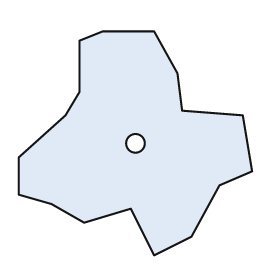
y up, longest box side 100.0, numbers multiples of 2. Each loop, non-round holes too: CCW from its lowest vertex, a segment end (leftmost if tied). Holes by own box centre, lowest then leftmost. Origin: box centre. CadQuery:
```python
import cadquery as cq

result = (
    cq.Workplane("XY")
    .moveTo(8.0, -48.0)
    .lineTo(24.0, -40.0)
    .lineTo(36.0, -18.0)
    .lineTo(50.0, -12.0)
    .lineTo(46.0, 12.0)
    .lineTo(20.0, 14.0)
    .lineTo(18.0, 30.0)
    .lineTo(8.0, 48.0)
    .lineTo(-14.0, 48.0)
    .lineTo(-24.0, 44.0)
    .lineTo(-24.0, 22.0)
    .lineTo(-30.0, 12.0)
    .lineTo(-50.0, -6.0)
    .lineTo(-50.0, -22.0)
    .lineTo(-36.0, -26.0)
    .lineTo(-22.0, -34.0)
    .lineTo(-2.0, -28.0)
    .close()
    .moveTo(0.0, 0.0)
    .circle(4.0)
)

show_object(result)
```